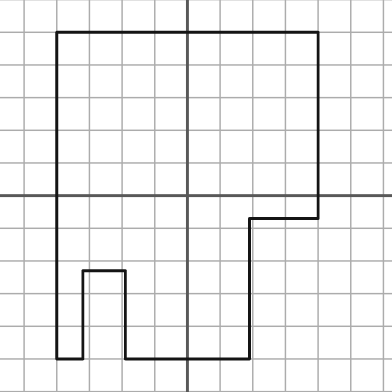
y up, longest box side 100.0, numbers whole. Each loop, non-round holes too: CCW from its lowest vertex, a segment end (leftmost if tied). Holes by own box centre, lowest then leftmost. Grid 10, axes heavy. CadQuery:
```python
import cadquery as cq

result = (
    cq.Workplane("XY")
    .moveTo(-40.0, -50.0)
    .lineTo(-32.0, -50.0)
    .lineTo(-32.0, -23.0)
    .lineTo(-19.0, -23.0)
    .lineTo(-19.0, -50.0)
    .lineTo(19.0, -50.0)
    .lineTo(19.0, -7.0)
    .lineTo(40.0, -7.0)
    .lineTo(40.0, 50.0)
    .lineTo(-40.0, 50.0)
    .close()
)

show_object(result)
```